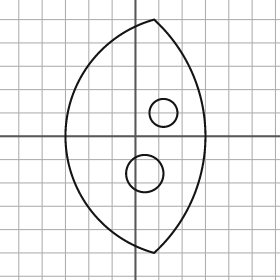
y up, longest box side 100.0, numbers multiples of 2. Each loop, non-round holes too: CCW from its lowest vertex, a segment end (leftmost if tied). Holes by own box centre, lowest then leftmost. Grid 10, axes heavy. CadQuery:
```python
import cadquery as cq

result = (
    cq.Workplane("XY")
    .moveTo(8.0, -50.0)
    .threePointArc((30.0, 0.0), (8.0, 50.0))
    .threePointArc((-30.0, 0.0), (8.0, -50.0))
    .close()
    .moveTo(4.0, -16.0)
    .circle(8.0)
    .moveTo(12.0, 10.0)
    .circle(6.0)
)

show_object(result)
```